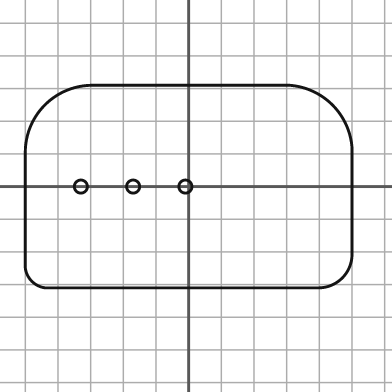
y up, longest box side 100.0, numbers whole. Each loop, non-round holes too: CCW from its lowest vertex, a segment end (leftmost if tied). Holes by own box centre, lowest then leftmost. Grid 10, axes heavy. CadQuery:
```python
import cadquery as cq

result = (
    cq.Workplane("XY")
    .moveTo(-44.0, -31.0)
    .lineTo(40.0, -31.0)
    .threePointArc((47.0, -28.0), (50.0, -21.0))
    .lineTo(50.0, 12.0)
    .threePointArc((44.0, 25.0), (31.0, 31.0))
    .lineTo(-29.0, 31.0)
    .threePointArc((-44.0, 25.0), (-50.0, 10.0))
    .lineTo(-50.0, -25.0)
    .threePointArc((-48.0, -29.0), (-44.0, -31.0))
    .close()
    .moveTo(-33.0, 0.0)
    .circle(2.0)
    .moveTo(-17.0, 0.0)
    .circle(2.0)
    .moveTo(-1.0, 0.0)
    .circle(2.0)
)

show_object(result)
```